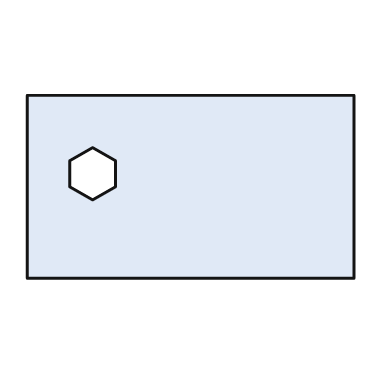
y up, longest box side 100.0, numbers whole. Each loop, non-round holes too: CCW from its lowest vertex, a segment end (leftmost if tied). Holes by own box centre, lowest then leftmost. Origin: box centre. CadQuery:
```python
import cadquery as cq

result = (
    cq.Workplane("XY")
    .moveTo(-50.0, -28.0)
    .lineTo(50.0, -28.0)
    .lineTo(50.0, 28.0)
    .lineTo(-50.0, 28.0)
    .close()
    .moveTo(-30.0, -4.0)
    .lineTo(-23.0, 0.0)
    .lineTo(-23.0, 8.0)
    .lineTo(-30.0, 12.0)
    .lineTo(-37.0, 8.0)
    .lineTo(-37.0, 0.0)
    .close()
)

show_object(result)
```